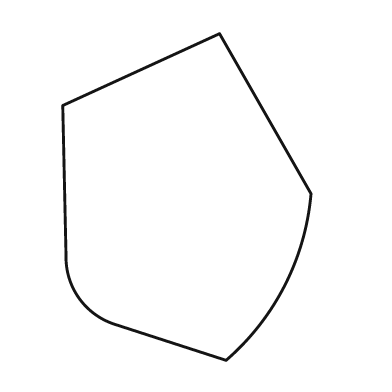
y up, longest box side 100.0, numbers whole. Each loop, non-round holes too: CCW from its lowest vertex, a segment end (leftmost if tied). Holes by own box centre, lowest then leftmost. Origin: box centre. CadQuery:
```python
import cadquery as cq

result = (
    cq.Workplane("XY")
    .moveTo(12.0, -50.0)
    .threePointArc((30.0, -27.0), (38.0, 1.0))
    .lineTo(10.0, 50.0)
    .lineTo(-38.0, 28.0)
    .lineTo(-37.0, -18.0)
    .threePointArc((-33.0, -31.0), (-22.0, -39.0))
    .close()
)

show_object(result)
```